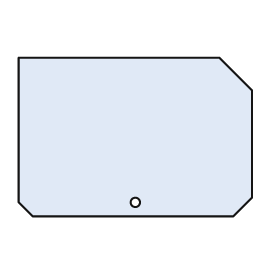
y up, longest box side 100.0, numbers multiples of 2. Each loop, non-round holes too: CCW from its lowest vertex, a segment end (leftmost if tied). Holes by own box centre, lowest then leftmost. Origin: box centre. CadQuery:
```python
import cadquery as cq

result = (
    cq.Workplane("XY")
    .moveTo(-44.0, -34.0)
    .lineTo(42.0, -34.0)
    .lineTo(50.0, -26.0)
    .lineTo(50.0, 20.0)
    .lineTo(36.0, 34.0)
    .lineTo(-50.0, 34.0)
    .lineTo(-50.0, -28.0)
    .close()
    .moveTo(0.0, -28.0)
    .circle(2.0)
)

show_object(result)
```